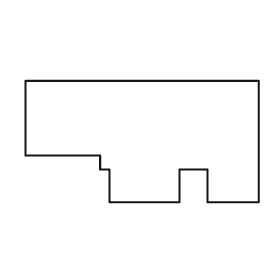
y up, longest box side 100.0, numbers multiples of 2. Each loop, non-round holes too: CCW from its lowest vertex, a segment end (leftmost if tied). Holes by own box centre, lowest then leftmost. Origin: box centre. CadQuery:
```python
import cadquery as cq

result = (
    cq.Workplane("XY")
    .moveTo(-14.0, -26.0)
    .lineTo(16.0, -26.0)
    .lineTo(16.0, -12.0)
    .lineTo(28.0, -12.0)
    .lineTo(28.0, -26.0)
    .lineTo(50.0, -26.0)
    .lineTo(50.0, 26.0)
    .lineTo(-50.0, 26.0)
    .lineTo(-50.0, -6.0)
    .lineTo(-18.0, -6.0)
    .lineTo(-18.0, -12.0)
    .lineTo(-14.0, -12.0)
    .close()
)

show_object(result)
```